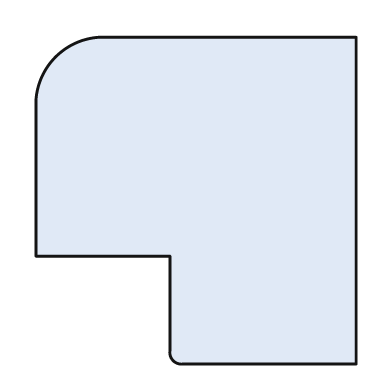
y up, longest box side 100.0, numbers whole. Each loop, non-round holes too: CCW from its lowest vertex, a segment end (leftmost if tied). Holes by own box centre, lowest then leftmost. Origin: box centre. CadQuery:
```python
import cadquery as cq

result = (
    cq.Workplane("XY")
    .moveTo(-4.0, -50.0)
    .lineTo(49.0, -50.0)
    .lineTo(49.0, 50.0)
    .lineTo(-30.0, 50.0)
    .threePointArc((-43.0, 44.0), (-49.0, 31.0))
    .lineTo(-49.0, -17.0)
    .lineTo(-8.0, -17.0)
    .lineTo(-8.0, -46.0)
    .threePointArc((-7.0, -49.0), (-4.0, -50.0))
    .close()
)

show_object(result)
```